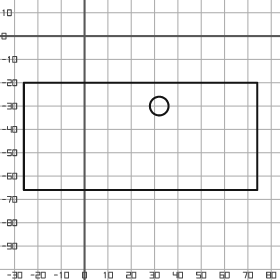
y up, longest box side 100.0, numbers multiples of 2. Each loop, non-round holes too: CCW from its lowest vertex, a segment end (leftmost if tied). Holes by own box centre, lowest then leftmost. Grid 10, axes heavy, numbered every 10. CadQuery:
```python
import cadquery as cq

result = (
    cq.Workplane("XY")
    .moveTo(-26.0, -66.0)
    .lineTo(74.0, -66.0)
    .lineTo(74.0, -20.0)
    .lineTo(-26.0, -20.0)
    .close()
    .moveTo(32.0, -30.0)
    .circle(4.0)
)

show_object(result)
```